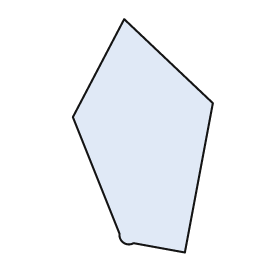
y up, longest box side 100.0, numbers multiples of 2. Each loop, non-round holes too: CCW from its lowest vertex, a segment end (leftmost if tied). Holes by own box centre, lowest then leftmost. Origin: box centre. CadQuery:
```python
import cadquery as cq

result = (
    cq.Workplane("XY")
    .moveTo(18.0, -50.0)
    .lineTo(30.0, 14.0)
    .lineTo(-8.0, 50.0)
    .lineTo(-30.0, 8.0)
    .lineTo(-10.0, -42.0)
    .threePointArc((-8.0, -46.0), (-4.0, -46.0))
    .close()
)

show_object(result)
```